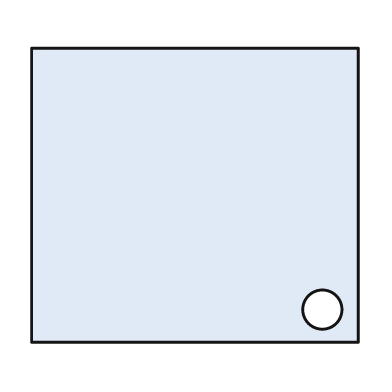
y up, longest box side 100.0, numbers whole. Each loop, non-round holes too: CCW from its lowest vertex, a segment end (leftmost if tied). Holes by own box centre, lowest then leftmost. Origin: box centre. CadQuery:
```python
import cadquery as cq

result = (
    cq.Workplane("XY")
    .moveTo(-50.0, -45.0)
    .lineTo(50.0, -45.0)
    .lineTo(50.0, 45.0)
    .lineTo(-50.0, 45.0)
    .close()
    .moveTo(39.0, -35.0)
    .circle(6.0)
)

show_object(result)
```